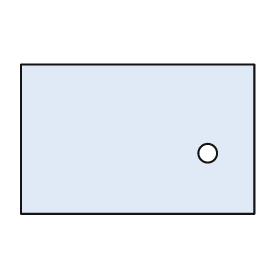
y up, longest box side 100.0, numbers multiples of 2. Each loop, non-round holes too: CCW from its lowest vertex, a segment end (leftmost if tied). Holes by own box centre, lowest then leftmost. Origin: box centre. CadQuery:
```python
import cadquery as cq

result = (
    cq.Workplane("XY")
    .moveTo(-50.0, -32.0)
    .lineTo(50.0, -32.0)
    .lineTo(50.0, 32.0)
    .lineTo(-50.0, 32.0)
    .close()
    .moveTo(30.0, -6.0)
    .circle(4.0)
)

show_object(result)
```